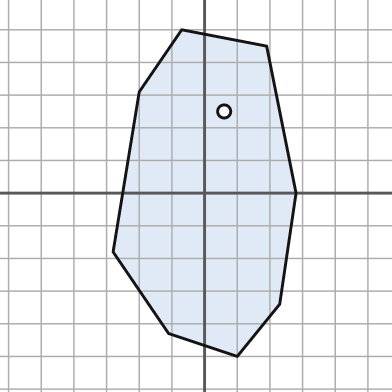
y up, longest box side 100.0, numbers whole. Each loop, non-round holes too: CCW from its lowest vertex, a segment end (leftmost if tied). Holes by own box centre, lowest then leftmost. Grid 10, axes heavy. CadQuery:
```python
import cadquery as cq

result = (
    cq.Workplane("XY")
    .moveTo(10.0, -50.0)
    .lineTo(23.0, -34.0)
    .lineTo(28.0, 0.0)
    .lineTo(19.0, 45.0)
    .lineTo(-7.0, 50.0)
    .lineTo(-20.0, 31.0)
    .lineTo(-28.0, -18.0)
    .lineTo(-11.0, -43.0)
    .close()
    .moveTo(6.0, 25.0)
    .circle(2.0)
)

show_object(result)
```